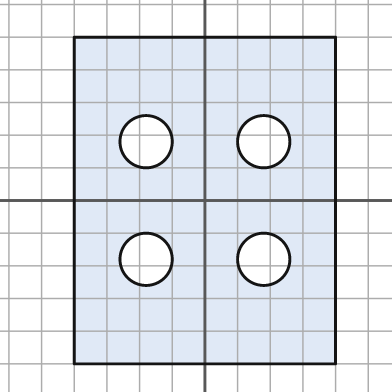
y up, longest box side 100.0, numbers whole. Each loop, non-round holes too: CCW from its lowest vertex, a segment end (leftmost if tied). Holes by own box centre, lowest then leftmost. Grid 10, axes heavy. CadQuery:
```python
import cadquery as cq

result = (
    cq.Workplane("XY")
    .moveTo(-40.0, -50.0)
    .lineTo(40.0, -50.0)
    .lineTo(40.0, 50.0)
    .lineTo(-40.0, 50.0)
    .close()
    .moveTo(-18.0, -18.0)
    .circle(8.0)
    .moveTo(18.0, -18.0)
    .circle(8.0)
    .moveTo(-18.0, 18.0)
    .circle(8.0)
    .moveTo(18.0, 18.0)
    .circle(8.0)
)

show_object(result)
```